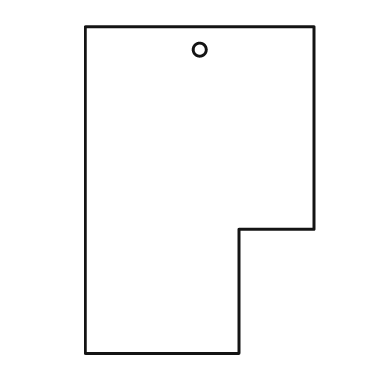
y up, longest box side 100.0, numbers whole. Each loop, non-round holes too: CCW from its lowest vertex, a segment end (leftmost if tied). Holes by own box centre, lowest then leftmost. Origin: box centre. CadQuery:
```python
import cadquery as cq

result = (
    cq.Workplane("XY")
    .moveTo(-35.0, -50.0)
    .lineTo(12.0, -50.0)
    .lineTo(12.0, -12.0)
    .lineTo(35.0, -12.0)
    .lineTo(35.0, 50.0)
    .lineTo(-35.0, 50.0)
    .close()
    .moveTo(0.0, 43.0)
    .circle(2.0)
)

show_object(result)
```